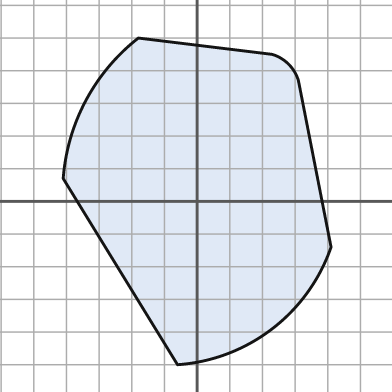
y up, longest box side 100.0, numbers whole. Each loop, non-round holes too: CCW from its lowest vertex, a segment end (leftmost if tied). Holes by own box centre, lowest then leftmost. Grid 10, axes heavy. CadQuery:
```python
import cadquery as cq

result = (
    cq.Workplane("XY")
    .moveTo(-6.0, -50.0)
    .threePointArc((23.0, -39.0), (41.0, -14.0))
    .lineTo(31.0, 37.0)
    .threePointArc((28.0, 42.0), (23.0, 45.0))
    .lineTo(-18.0, 50.0)
    .threePointArc((-34.0, 31.0), (-41.0, 7.0))
    .close()
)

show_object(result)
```